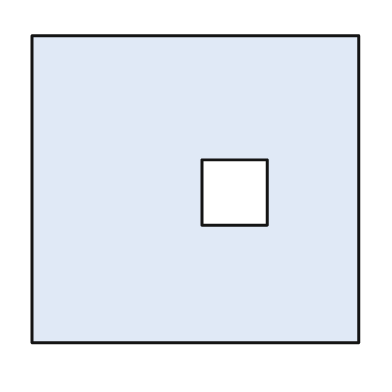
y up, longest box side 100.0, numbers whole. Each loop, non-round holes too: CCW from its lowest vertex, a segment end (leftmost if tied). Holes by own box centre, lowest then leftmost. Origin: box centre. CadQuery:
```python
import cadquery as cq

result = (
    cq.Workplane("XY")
    .moveTo(-50.0, -47.0)
    .lineTo(50.0, -47.0)
    .lineTo(50.0, 47.0)
    .lineTo(-50.0, 47.0)
    .close()
    .moveTo(2.0, -11.0)
    .lineTo(22.0, -11.0)
    .lineTo(22.0, 9.0)
    .lineTo(2.0, 9.0)
    .close()
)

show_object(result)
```